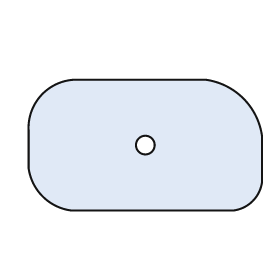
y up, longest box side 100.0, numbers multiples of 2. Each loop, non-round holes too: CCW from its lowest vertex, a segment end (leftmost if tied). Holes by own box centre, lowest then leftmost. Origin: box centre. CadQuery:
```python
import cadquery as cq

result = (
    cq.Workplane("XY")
    .moveTo(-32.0, -28.0)
    .lineTo(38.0, -28.0)
    .threePointArc((46.0, -24.0), (50.0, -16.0))
    .lineTo(50.0, 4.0)
    .threePointArc((42.0, 20.0), (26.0, 28.0))
    .lineTo(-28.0, 28.0)
    .threePointArc((-44.0, 22.0), (-50.0, 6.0))
    .lineTo(-50.0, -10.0)
    .threePointArc((-44.0, -22.0), (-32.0, -28.0))
    .close()
    .moveTo(0.0, 0.0)
    .circle(4.0)
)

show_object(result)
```